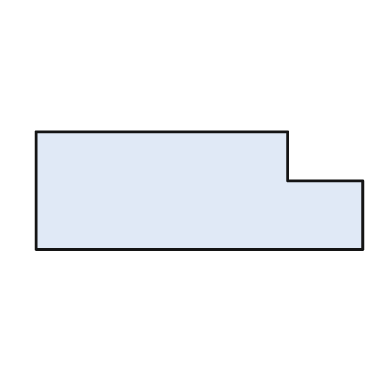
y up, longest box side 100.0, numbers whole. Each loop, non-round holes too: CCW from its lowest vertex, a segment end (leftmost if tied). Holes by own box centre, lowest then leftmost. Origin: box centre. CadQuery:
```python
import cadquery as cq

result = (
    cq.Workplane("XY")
    .moveTo(-50.0, -18.0)
    .lineTo(50.0, -18.0)
    .lineTo(50.0, 3.0)
    .lineTo(27.0, 3.0)
    .lineTo(27.0, 18.0)
    .lineTo(-50.0, 18.0)
    .close()
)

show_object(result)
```